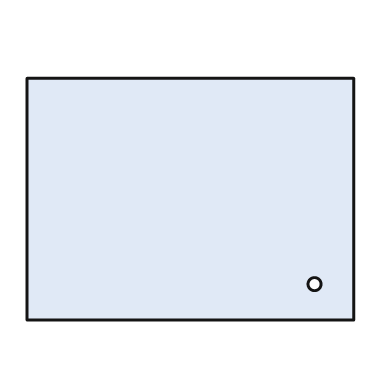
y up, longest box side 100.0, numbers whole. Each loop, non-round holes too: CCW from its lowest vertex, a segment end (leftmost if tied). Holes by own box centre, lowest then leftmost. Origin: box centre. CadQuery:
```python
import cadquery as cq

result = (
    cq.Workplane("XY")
    .moveTo(-50.0, -37.0)
    .lineTo(50.0, -37.0)
    .lineTo(50.0, 37.0)
    .lineTo(-50.0, 37.0)
    .close()
    .moveTo(38.0, -26.0)
    .circle(2.0)
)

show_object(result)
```